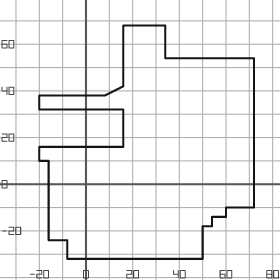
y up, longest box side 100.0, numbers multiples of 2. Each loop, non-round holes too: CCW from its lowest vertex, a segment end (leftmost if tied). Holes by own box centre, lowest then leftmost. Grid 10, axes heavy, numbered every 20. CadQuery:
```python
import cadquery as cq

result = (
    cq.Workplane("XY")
    .moveTo(-8.0, -32.0)
    .lineTo(50.0, -32.0)
    .lineTo(50.0, -18.0)
    .lineTo(54.0, -18.0)
    .lineTo(54.0, -14.0)
    .lineTo(60.0, -14.0)
    .lineTo(60.0, -10.0)
    .lineTo(72.0, -10.0)
    .lineTo(72.0, 54.0)
    .lineTo(34.0, 54.0)
    .lineTo(34.0, 68.0)
    .lineTo(16.0, 68.0)
    .lineTo(16.0, 42.0)
    .lineTo(8.0, 38.0)
    .lineTo(-20.0, 38.0)
    .lineTo(-20.0, 32.0)
    .lineTo(16.0, 32.0)
    .lineTo(16.0, 16.0)
    .lineTo(-20.0, 16.0)
    .lineTo(-20.0, 10.0)
    .lineTo(-16.0, 10.0)
    .lineTo(-16.0, -24.0)
    .lineTo(-8.0, -24.0)
    .close()
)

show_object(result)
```